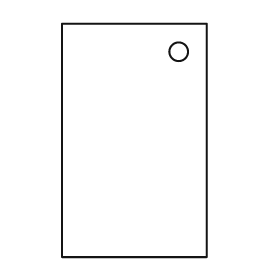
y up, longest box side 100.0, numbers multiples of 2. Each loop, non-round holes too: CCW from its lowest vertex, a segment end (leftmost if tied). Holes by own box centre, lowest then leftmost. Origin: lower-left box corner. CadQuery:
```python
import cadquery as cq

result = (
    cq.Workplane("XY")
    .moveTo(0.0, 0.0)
    .lineTo(62.0, 0.0)
    .lineTo(62.0, 100.0)
    .lineTo(0.0, 100.0)
    .close()
    .moveTo(50.0, 88.0)
    .circle(4.0)
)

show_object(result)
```